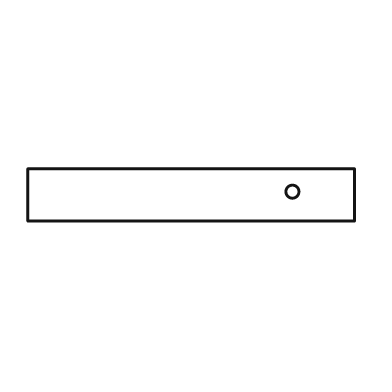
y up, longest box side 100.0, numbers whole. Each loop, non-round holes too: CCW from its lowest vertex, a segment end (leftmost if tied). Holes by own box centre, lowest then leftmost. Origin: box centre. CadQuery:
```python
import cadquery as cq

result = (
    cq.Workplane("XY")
    .moveTo(-50.0, -8.0)
    .lineTo(50.0, -8.0)
    .lineTo(50.0, 8.0)
    .lineTo(-50.0, 8.0)
    .close()
    .moveTo(31.0, 1.0)
    .circle(2.0)
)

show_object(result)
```